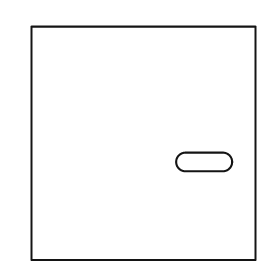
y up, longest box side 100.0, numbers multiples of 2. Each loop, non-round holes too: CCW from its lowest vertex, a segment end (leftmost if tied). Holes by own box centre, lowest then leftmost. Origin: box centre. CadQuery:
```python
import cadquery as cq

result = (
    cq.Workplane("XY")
    .moveTo(-48.0, -50.0)
    .lineTo(48.0, -50.0)
    .lineTo(48.0, 50.0)
    .lineTo(-48.0, 50.0)
    .close()
    .moveTo(18.0, -12.0)
    .lineTo(34.0, -12.0)
    .threePointArc((38.0, -8.0), (34.0, -4.0))
    .lineTo(18.0, -4.0)
    .threePointArc((14.0, -8.0), (18.0, -12.0))
    .close()
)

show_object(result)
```